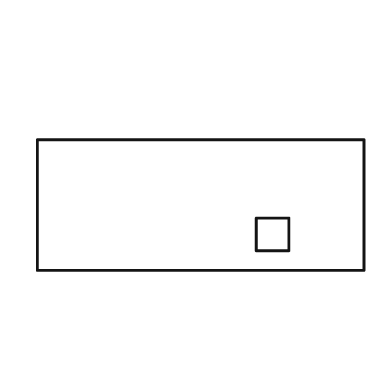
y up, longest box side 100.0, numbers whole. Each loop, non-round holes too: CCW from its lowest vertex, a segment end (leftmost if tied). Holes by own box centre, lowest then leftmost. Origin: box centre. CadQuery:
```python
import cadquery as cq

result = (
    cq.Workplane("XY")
    .moveTo(-50.0, -20.0)
    .lineTo(50.0, -20.0)
    .lineTo(50.0, 20.0)
    .lineTo(-50.0, 20.0)
    .close()
    .moveTo(17.0, -14.0)
    .lineTo(27.0, -14.0)
    .lineTo(27.0, -4.0)
    .lineTo(17.0, -4.0)
    .close()
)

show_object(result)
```